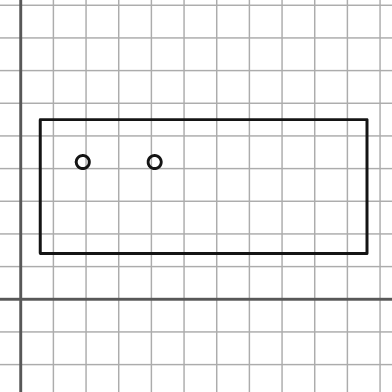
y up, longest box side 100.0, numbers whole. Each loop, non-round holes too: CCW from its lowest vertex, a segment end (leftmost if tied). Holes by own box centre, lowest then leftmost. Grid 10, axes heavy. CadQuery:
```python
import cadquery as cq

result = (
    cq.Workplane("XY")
    .moveTo(6.0, 14.0)
    .lineTo(106.0, 14.0)
    .lineTo(106.0, 55.0)
    .lineTo(6.0, 55.0)
    .close()
    .moveTo(19.0, 42.0)
    .circle(2.0)
    .moveTo(41.0, 42.0)
    .circle(2.0)
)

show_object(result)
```